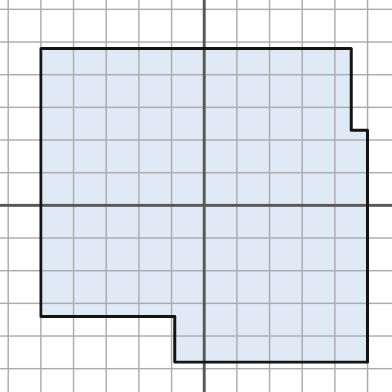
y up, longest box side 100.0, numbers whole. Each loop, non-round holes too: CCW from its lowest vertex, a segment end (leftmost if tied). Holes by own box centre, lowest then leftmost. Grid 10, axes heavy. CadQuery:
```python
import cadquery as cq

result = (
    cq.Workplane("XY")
    .moveTo(-9.0, -48.0)
    .lineTo(50.0, -48.0)
    .lineTo(50.0, 23.0)
    .lineTo(45.0, 23.0)
    .lineTo(45.0, 48.0)
    .lineTo(-50.0, 48.0)
    .lineTo(-50.0, -34.0)
    .lineTo(-9.0, -34.0)
    .close()
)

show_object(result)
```